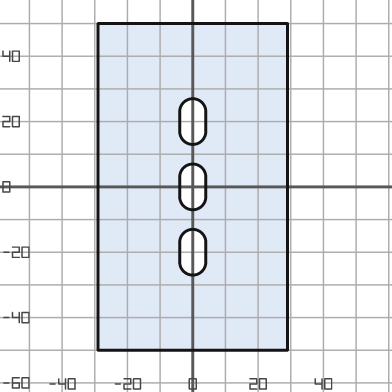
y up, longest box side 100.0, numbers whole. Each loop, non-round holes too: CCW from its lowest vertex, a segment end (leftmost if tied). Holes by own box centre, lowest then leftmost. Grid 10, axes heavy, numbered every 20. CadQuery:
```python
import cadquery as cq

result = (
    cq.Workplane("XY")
    .moveTo(-29.0, -50.0)
    .lineTo(29.0, -50.0)
    .lineTo(29.0, 50.0)
    .lineTo(-29.0, 50.0)
    .close()
    .moveTo(-4.0, -23.0)
    .threePointArc((0.0, -27.0), (4.0, -23.0))
    .lineTo(4.0, -17.0)
    .threePointArc((0.0, -13.0), (-4.0, -17.0))
    .close()
    .moveTo(-4.0, -3.0)
    .threePointArc((0.0, -7.0), (4.0, -3.0))
    .lineTo(4.0, 3.0)
    .threePointArc((0.0, 7.0), (-4.0, 3.0))
    .close()
    .moveTo(-4.0, 17.0)
    .threePointArc((0.0, 13.0), (4.0, 17.0))
    .lineTo(4.0, 23.0)
    .threePointArc((0.0, 27.0), (-4.0, 23.0))
    .close()
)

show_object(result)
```